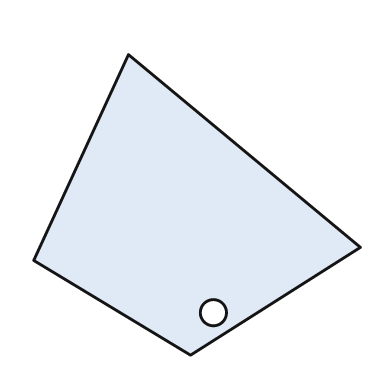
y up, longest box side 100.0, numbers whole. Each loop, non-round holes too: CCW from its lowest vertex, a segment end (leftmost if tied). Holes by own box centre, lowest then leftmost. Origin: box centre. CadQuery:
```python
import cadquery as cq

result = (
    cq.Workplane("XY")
    .moveTo(-2.0, -46.0)
    .lineTo(50.0, -13.0)
    .lineTo(-21.0, 46.0)
    .lineTo(-50.0, -17.0)
    .close()
    .moveTo(5.0, -33.0)
    .circle(4.0)
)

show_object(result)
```